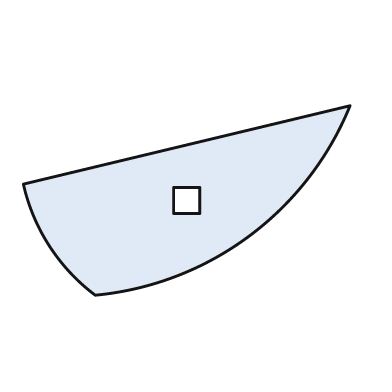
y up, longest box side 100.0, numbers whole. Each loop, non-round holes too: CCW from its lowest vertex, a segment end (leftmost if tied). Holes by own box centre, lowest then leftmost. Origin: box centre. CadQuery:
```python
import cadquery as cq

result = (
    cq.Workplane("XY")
    .moveTo(-28.0, -29.0)
    .threePointArc((19.0, -11.0), (50.0, 29.0))
    .lineTo(-50.0, 5.0)
    .threePointArc((-42.0, -14.0), (-28.0, -29.0))
    .close()
    .moveTo(-4.0, -4.0)
    .lineTo(4.0, -4.0)
    .lineTo(4.0, 4.0)
    .lineTo(-4.0, 4.0)
    .close()
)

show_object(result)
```